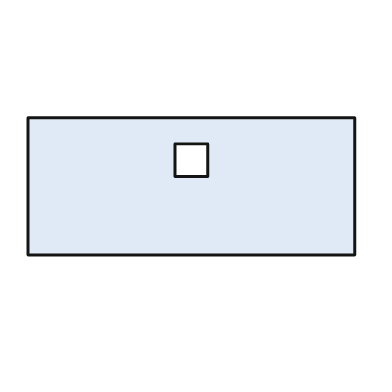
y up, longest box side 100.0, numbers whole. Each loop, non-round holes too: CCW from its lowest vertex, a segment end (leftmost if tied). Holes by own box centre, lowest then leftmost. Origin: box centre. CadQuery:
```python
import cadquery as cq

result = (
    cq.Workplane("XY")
    .moveTo(-50.0, -21.0)
    .lineTo(50.0, -21.0)
    .lineTo(50.0, 21.0)
    .lineTo(-50.0, 21.0)
    .close()
    .moveTo(-5.0, 3.0)
    .lineTo(5.0, 3.0)
    .lineTo(5.0, 13.0)
    .lineTo(-5.0, 13.0)
    .close()
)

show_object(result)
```